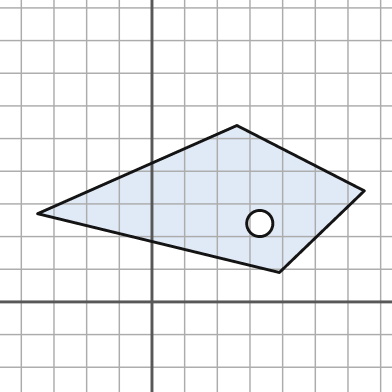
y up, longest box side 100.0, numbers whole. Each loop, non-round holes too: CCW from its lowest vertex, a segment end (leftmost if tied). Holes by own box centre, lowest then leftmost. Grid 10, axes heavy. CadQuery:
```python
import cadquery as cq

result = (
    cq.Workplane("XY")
    .moveTo(39.0, 9.0)
    .lineTo(65.0, 34.0)
    .lineTo(26.0, 54.0)
    .lineTo(-35.0, 27.0)
    .close()
    .moveTo(33.0, 24.0)
    .circle(4.0)
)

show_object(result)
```